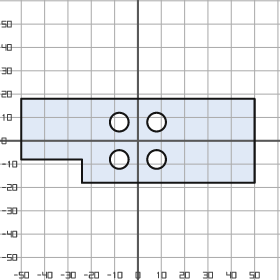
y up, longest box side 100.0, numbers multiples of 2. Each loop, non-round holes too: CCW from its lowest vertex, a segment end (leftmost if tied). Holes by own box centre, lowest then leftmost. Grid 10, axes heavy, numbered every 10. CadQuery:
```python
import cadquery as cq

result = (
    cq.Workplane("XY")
    .moveTo(-24.0, -18.0)
    .lineTo(50.0, -18.0)
    .lineTo(50.0, 18.0)
    .lineTo(-50.0, 18.0)
    .lineTo(-50.0, -8.0)
    .lineTo(-24.0, -8.0)
    .close()
    .moveTo(-8.0, -8.0)
    .circle(4.0)
    .moveTo(8.0, -8.0)
    .circle(4.0)
    .moveTo(-8.0, 8.0)
    .circle(4.0)
    .moveTo(8.0, 8.0)
    .circle(4.0)
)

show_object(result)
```